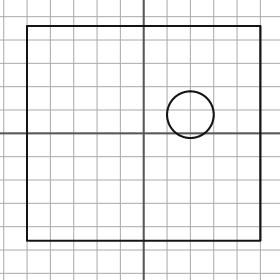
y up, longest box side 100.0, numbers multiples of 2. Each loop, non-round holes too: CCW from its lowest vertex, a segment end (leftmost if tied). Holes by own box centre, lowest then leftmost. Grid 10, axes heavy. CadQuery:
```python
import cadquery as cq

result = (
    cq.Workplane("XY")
    .moveTo(-50.0, -46.0)
    .lineTo(50.0, -46.0)
    .lineTo(50.0, 46.0)
    .lineTo(-50.0, 46.0)
    .close()
    .moveTo(20.0, 8.0)
    .circle(10.0)
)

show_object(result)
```